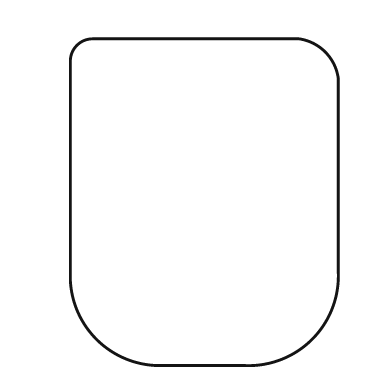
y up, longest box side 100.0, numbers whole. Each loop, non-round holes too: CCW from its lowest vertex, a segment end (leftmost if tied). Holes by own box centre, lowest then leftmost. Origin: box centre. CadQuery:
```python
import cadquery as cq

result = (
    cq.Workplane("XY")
    .moveTo(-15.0, -50.0)
    .lineTo(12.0, -50.0)
    .threePointArc((33.0, -42.0), (41.0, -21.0))
    .lineTo(41.0, 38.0)
    .threePointArc((37.0, 46.0), (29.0, 50.0))
    .lineTo(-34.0, 50.0)
    .threePointArc((-39.0, 48.0), (-41.0, 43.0))
    .lineTo(-41.0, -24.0)
    .threePointArc((-33.0, -42.0), (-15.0, -50.0))
    .close()
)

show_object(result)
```